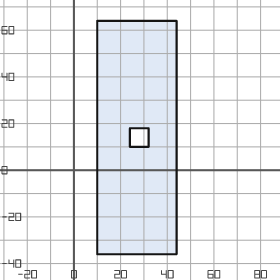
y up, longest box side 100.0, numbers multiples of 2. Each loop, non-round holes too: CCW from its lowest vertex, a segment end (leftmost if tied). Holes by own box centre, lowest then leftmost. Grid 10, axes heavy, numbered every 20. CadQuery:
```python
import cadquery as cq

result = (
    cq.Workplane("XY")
    .moveTo(10.0, -36.0)
    .lineTo(44.0, -36.0)
    .lineTo(44.0, 64.0)
    .lineTo(10.0, 64.0)
    .close()
    .moveTo(24.0, 10.0)
    .lineTo(32.0, 10.0)
    .lineTo(32.0, 18.0)
    .lineTo(24.0, 18.0)
    .close()
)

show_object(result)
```